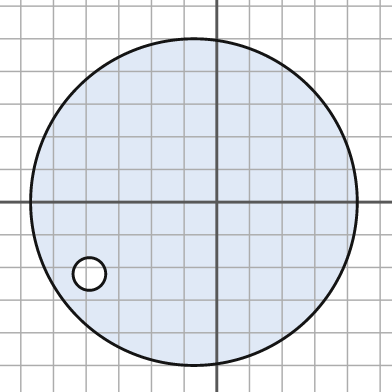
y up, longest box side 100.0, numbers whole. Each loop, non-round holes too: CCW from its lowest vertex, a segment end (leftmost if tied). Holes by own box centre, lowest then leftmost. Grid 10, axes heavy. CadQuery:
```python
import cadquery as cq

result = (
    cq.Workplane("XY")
    .moveTo(-7.0, 0.0)
    .circle(50.0)
    .moveTo(-39.0, -22.0)
    .circle(5.0)
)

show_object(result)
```